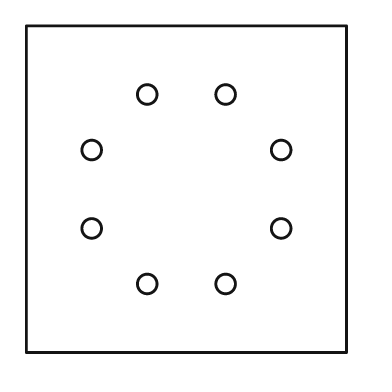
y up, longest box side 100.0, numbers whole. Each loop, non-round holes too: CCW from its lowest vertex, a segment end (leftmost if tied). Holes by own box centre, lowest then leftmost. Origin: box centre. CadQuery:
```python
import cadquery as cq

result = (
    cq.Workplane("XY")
    .moveTo(-49.0, -50.0)
    .lineTo(49.0, -50.0)
    .lineTo(49.0, 50.0)
    .lineTo(-49.0, 50.0)
    .close()
    .moveTo(-12.0, -29.0)
    .circle(3.0)
    .moveTo(12.0, -29.0)
    .circle(3.0)
    .moveTo(-29.0, -12.0)
    .circle(3.0)
    .moveTo(29.0, -12.0)
    .circle(3.0)
    .moveTo(-29.0, 12.0)
    .circle(3.0)
    .moveTo(29.0, 12.0)
    .circle(3.0)
    .moveTo(-12.0, 29.0)
    .circle(3.0)
    .moveTo(12.0, 29.0)
    .circle(3.0)
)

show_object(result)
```